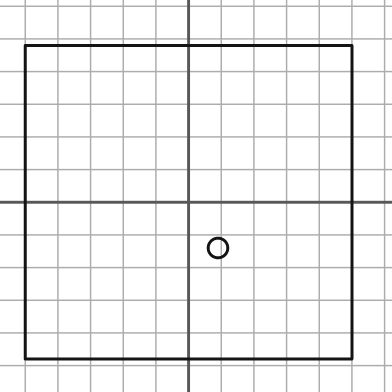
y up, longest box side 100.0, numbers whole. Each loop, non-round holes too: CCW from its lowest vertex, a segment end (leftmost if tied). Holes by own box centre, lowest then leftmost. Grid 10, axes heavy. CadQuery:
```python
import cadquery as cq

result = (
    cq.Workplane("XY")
    .moveTo(-50.0, -48.0)
    .lineTo(50.0, -48.0)
    .lineTo(50.0, 48.0)
    .lineTo(-50.0, 48.0)
    .close()
    .moveTo(9.0, -14.0)
    .circle(3.0)
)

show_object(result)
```